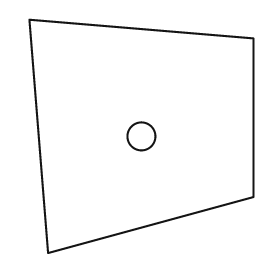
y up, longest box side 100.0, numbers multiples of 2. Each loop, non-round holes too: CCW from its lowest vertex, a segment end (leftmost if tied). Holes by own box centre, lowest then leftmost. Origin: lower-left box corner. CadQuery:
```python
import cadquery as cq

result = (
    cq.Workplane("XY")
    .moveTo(8.0, 0.0)
    .lineTo(96.0, 24.0)
    .lineTo(96.0, 92.0)
    .lineTo(0.0, 100.0)
    .close()
    .moveTo(48.0, 50.0)
    .circle(6.0)
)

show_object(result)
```